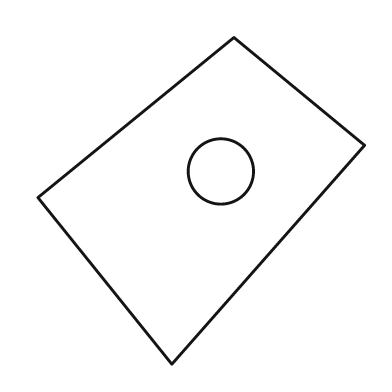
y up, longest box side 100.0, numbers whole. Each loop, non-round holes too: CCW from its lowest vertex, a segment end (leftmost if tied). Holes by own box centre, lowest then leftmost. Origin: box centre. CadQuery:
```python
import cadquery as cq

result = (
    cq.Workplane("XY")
    .moveTo(-9.0, -50.0)
    .lineTo(50.0, 17.0)
    .lineTo(10.0, 50.0)
    .lineTo(-50.0, 1.0)
    .close()
    .moveTo(6.0, 9.0)
    .circle(10.0)
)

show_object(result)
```